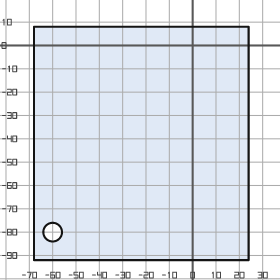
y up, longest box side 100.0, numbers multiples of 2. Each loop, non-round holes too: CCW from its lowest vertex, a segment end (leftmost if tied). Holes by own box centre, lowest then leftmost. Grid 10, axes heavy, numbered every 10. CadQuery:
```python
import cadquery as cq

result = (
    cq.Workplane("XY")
    .moveTo(-68.0, -92.0)
    .lineTo(24.0, -92.0)
    .lineTo(24.0, 8.0)
    .lineTo(-68.0, 8.0)
    .close()
    .moveTo(-60.0, -80.0)
    .circle(4.0)
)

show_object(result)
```